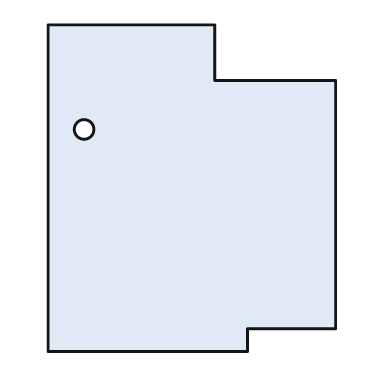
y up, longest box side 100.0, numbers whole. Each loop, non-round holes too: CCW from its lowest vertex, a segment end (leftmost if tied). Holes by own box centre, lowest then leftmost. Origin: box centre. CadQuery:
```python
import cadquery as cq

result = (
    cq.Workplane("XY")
    .moveTo(-44.0, -50.0)
    .lineTo(17.0, -50.0)
    .lineTo(17.0, -43.0)
    .lineTo(44.0, -43.0)
    .lineTo(44.0, 33.0)
    .lineTo(7.0, 33.0)
    .lineTo(7.0, 50.0)
    .lineTo(-44.0, 50.0)
    .close()
    .moveTo(-33.0, 18.0)
    .circle(3.0)
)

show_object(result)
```